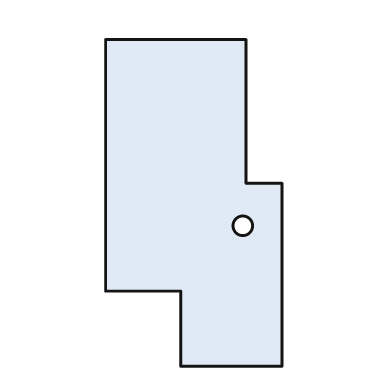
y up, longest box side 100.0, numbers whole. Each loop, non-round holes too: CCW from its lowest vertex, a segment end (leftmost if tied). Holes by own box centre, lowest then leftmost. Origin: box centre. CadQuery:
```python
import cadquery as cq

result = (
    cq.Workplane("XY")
    .moveTo(-4.0, -50.0)
    .lineTo(27.0, -50.0)
    .lineTo(27.0, 6.0)
    .lineTo(16.0, 6.0)
    .lineTo(16.0, 50.0)
    .lineTo(-27.0, 50.0)
    .lineTo(-27.0, -27.0)
    .lineTo(-4.0, -27.0)
    .close()
    .moveTo(15.0, -7.0)
    .circle(3.0)
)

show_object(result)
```